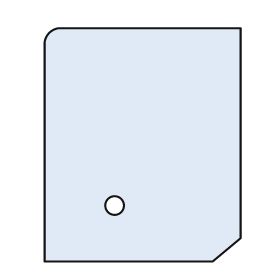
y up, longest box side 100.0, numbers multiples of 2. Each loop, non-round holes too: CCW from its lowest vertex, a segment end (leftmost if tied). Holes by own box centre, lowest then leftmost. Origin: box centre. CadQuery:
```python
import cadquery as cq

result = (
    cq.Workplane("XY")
    .moveTo(-42.0, -50.0)
    .lineTo(30.0, -50.0)
    .lineTo(42.0, -40.0)
    .lineTo(42.0, 50.0)
    .lineTo(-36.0, 50.0)
    .threePointArc((-40.0, 48.0), (-42.0, 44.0))
    .close()
    .moveTo(-12.0, -26.0)
    .circle(4.0)
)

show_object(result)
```